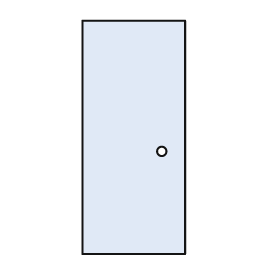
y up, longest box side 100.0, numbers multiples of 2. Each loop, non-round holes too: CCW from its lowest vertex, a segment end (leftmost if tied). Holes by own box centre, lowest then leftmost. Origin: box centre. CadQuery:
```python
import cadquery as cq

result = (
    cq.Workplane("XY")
    .moveTo(-22.0, -50.0)
    .lineTo(22.0, -50.0)
    .lineTo(22.0, 50.0)
    .lineTo(-22.0, 50.0)
    .close()
    .moveTo(12.0, -6.0)
    .circle(2.0)
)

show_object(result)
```